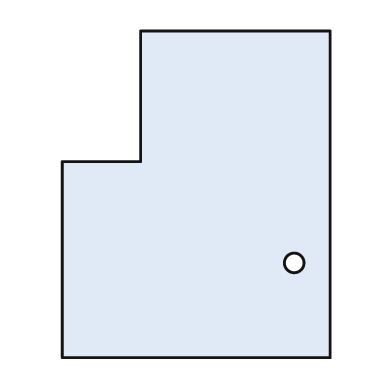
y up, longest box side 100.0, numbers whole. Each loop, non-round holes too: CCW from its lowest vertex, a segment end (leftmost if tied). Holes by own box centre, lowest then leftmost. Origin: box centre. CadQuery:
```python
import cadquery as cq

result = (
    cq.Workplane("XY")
    .moveTo(-41.0, -50.0)
    .lineTo(41.0, -50.0)
    .lineTo(41.0, 50.0)
    .lineTo(-17.0, 50.0)
    .lineTo(-17.0, 10.0)
    .lineTo(-41.0, 10.0)
    .close()
    .moveTo(30.0, -21.0)
    .circle(3.0)
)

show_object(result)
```